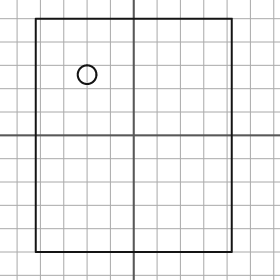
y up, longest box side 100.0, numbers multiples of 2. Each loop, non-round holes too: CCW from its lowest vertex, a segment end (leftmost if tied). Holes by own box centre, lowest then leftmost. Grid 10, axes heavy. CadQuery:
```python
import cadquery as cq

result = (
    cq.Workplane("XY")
    .moveTo(-42.0, -50.0)
    .lineTo(42.0, -50.0)
    .lineTo(42.0, 50.0)
    .lineTo(-42.0, 50.0)
    .close()
    .moveTo(-20.0, 26.0)
    .circle(4.0)
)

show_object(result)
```